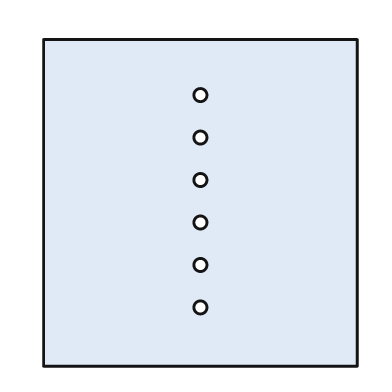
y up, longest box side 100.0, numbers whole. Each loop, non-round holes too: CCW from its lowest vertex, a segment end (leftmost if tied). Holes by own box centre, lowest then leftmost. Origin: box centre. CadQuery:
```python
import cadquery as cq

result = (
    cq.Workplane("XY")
    .moveTo(-48.0, -50.0)
    .lineTo(48.0, -50.0)
    .lineTo(48.0, 50.0)
    .lineTo(-48.0, 50.0)
    .close()
    .moveTo(0.0, -32.0)
    .circle(2.0)
    .moveTo(0.0, -19.0)
    .circle(2.0)
    .moveTo(0.0, -6.0)
    .circle(2.0)
    .moveTo(0.0, 7.0)
    .circle(2.0)
    .moveTo(0.0, 20.0)
    .circle(2.0)
    .moveTo(0.0, 33.0)
    .circle(2.0)
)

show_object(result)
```